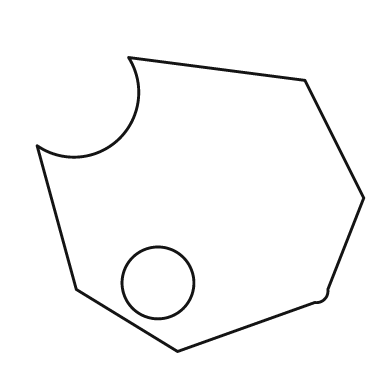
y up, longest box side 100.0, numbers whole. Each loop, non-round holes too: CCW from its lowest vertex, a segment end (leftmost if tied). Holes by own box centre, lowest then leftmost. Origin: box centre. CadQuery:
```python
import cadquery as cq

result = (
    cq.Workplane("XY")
    .moveTo(-7.0, -45.0)
    .lineTo(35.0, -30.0)
    .threePointArc((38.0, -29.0), (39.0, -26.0))
    .lineTo(50.0, 2.0)
    .lineTo(32.0, 38.0)
    .lineTo(-22.0, 45.0)
    .threePointArc((-25.0, 20.0), (-50.0, 18.0))
    .lineTo(-38.0, -26.0)
    .close()
    .moveTo(-13.0, -24.0)
    .circle(11.0)
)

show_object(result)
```